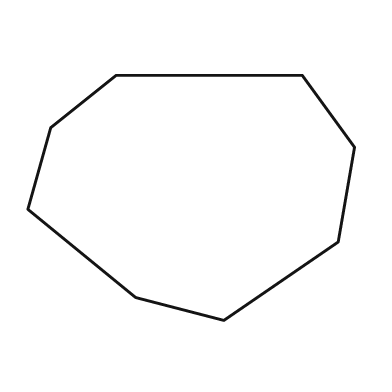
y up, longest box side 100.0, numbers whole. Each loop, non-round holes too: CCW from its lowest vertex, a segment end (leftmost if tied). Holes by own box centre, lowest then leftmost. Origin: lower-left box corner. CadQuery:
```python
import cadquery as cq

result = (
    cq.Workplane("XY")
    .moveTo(60.0, 0.0)
    .lineTo(95.0, 24.0)
    .lineTo(100.0, 53.0)
    .lineTo(84.0, 75.0)
    .lineTo(27.0, 75.0)
    .lineTo(7.0, 59.0)
    .lineTo(0.0, 34.0)
    .lineTo(33.0, 7.0)
    .close()
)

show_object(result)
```